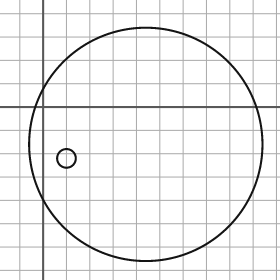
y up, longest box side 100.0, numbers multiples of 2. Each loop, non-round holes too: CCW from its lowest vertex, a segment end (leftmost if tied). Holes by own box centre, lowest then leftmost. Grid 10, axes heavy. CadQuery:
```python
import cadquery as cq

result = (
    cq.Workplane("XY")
    .moveTo(44.0, -16.0)
    .circle(50.0)
    .moveTo(10.0, -22.0)
    .circle(4.0)
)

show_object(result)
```